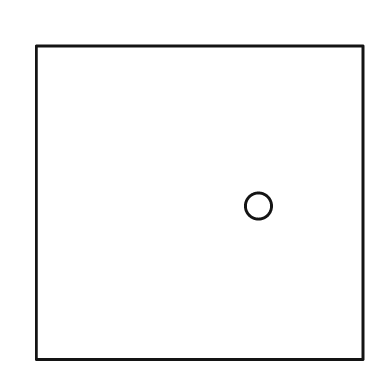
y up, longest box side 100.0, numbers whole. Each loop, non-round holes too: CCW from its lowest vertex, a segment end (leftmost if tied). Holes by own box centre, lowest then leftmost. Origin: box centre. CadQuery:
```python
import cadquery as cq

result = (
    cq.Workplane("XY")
    .moveTo(-50.0, -48.0)
    .lineTo(50.0, -48.0)
    .lineTo(50.0, 48.0)
    .lineTo(-50.0, 48.0)
    .close()
    .moveTo(18.0, -1.0)
    .circle(4.0)
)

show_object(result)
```